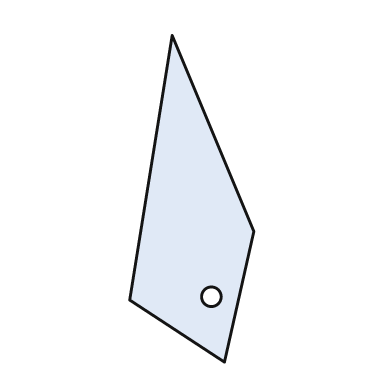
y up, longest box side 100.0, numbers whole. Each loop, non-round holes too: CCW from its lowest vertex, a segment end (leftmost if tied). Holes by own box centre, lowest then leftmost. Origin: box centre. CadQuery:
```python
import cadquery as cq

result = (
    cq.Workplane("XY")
    .moveTo(10.0, -50.0)
    .lineTo(19.0, -10.0)
    .lineTo(-6.0, 50.0)
    .lineTo(-19.0, -31.0)
    .close()
    .moveTo(6.0, -30.0)
    .circle(3.0)
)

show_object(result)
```